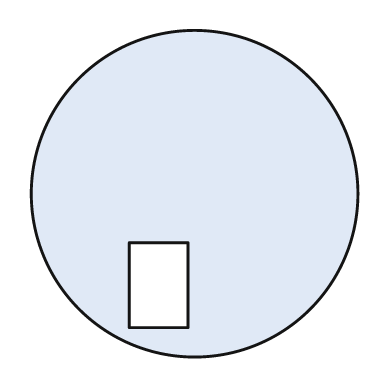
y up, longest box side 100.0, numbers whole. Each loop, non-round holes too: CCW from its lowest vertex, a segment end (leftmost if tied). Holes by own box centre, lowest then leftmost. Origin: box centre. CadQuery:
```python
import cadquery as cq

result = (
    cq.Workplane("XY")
    .moveTo(0.0, 0.0)
    .circle(50.0)
    .moveTo(-20.0, -41.0)
    .lineTo(-2.0, -41.0)
    .lineTo(-2.0, -15.0)
    .lineTo(-20.0, -15.0)
    .close()
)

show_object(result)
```